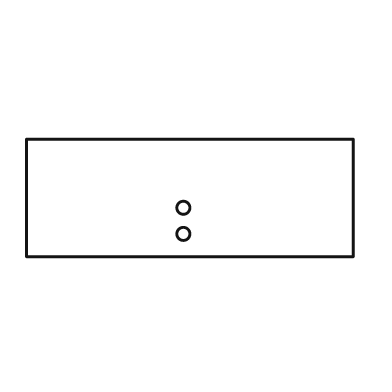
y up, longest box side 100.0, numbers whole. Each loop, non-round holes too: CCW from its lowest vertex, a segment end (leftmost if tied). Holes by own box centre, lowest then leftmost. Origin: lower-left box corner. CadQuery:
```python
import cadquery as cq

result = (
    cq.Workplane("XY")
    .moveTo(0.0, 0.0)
    .lineTo(100.0, 0.0)
    .lineTo(100.0, 36.0)
    .lineTo(0.0, 36.0)
    .close()
    .moveTo(48.0, 7.0)
    .circle(2.0)
    .moveTo(48.0, 15.0)
    .circle(2.0)
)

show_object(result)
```